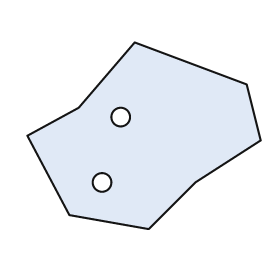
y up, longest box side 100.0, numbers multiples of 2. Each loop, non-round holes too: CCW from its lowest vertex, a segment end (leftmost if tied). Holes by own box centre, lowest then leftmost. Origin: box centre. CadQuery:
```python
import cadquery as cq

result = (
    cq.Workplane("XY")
    .moveTo(2.0, -40.0)
    .lineTo(22.0, -20.0)
    .lineTo(50.0, -2.0)
    .lineTo(44.0, 22.0)
    .lineTo(-4.0, 40.0)
    .lineTo(-28.0, 12.0)
    .lineTo(-50.0, 0.0)
    .lineTo(-32.0, -34.0)
    .close()
    .moveTo(-18.0, -20.0)
    .circle(4.0)
    .moveTo(-10.0, 8.0)
    .circle(4.0)
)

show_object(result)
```